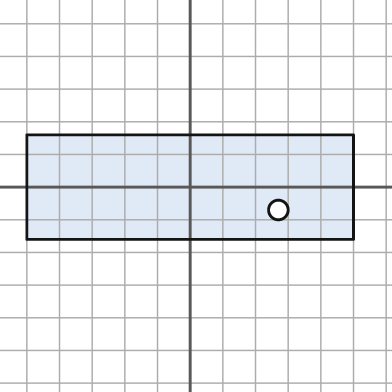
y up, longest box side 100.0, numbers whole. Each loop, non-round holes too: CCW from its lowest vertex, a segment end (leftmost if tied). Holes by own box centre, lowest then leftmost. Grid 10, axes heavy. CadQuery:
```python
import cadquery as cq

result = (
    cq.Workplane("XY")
    .moveTo(-50.0, -16.0)
    .lineTo(50.0, -16.0)
    .lineTo(50.0, 16.0)
    .lineTo(-50.0, 16.0)
    .close()
    .moveTo(27.0, -7.0)
    .circle(3.0)
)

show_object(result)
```